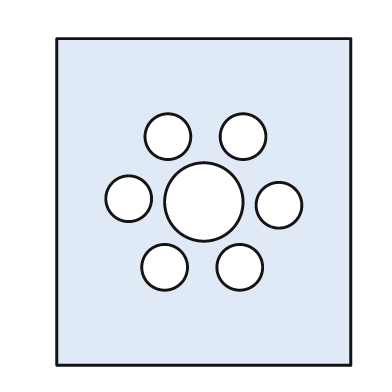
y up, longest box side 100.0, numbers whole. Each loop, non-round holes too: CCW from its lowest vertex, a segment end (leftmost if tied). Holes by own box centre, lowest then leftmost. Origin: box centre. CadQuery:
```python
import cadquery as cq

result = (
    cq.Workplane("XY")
    .moveTo(-45.0, -50.0)
    .lineTo(45.0, -50.0)
    .lineTo(45.0, 50.0)
    .lineTo(-45.0, 50.0)
    .close()
    .moveTo(-12.0, -20.0)
    .circle(7.0)
    .moveTo(11.0, -20.0)
    .circle(7.0)
    .moveTo(23.0, -1.0)
    .circle(7.0)
    .moveTo(0.0, 0.0)
    .circle(12.0)
    .moveTo(-23.0, 1.0)
    .circle(7.0)
    .moveTo(-11.0, 20.0)
    .circle(7.0)
    .moveTo(12.0, 20.0)
    .circle(7.0)
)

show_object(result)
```